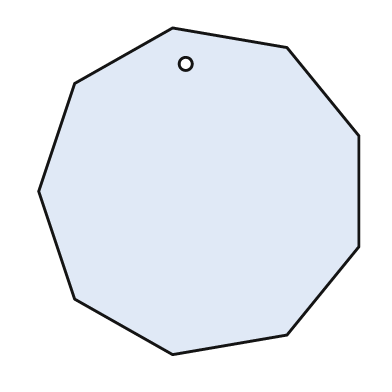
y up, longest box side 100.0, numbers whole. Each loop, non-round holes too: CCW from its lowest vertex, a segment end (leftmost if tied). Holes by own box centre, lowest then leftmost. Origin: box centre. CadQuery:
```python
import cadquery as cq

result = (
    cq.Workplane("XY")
    .moveTo(-8.0, -50.0)
    .lineTo(27.0, -44.0)
    .lineTo(49.0, -17.0)
    .lineTo(49.0, 17.0)
    .lineTo(27.0, 44.0)
    .lineTo(-8.0, 50.0)
    .lineTo(-38.0, 33.0)
    .lineTo(-49.0, 0.0)
    .lineTo(-38.0, -33.0)
    .close()
    .moveTo(-4.0, 39.0)
    .circle(2.0)
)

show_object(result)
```